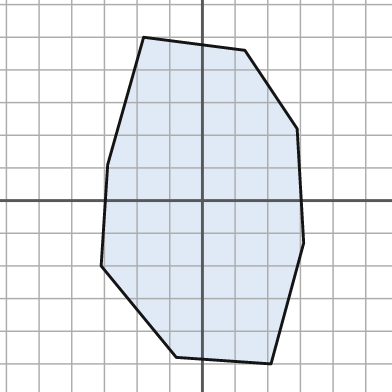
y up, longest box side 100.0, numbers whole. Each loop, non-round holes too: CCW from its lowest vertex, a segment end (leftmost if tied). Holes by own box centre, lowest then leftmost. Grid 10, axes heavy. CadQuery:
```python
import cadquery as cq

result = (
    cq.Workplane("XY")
    .moveTo(21.0, -50.0)
    .lineTo(31.0, -13.0)
    .lineTo(29.0, 22.0)
    .lineTo(13.0, 46.0)
    .lineTo(-18.0, 50.0)
    .lineTo(-29.0, 11.0)
    .lineTo(-31.0, -20.0)
    .lineTo(-8.0, -48.0)
    .close()
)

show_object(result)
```